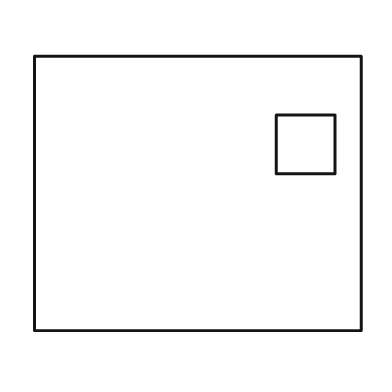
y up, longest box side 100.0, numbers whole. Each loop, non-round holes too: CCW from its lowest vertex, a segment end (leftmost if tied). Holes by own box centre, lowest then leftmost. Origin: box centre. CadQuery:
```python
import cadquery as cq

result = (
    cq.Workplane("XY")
    .moveTo(-50.0, -42.0)
    .lineTo(50.0, -42.0)
    .lineTo(50.0, 42.0)
    .lineTo(-50.0, 42.0)
    .close()
    .moveTo(24.0, 6.0)
    .lineTo(42.0, 6.0)
    .lineTo(42.0, 24.0)
    .lineTo(24.0, 24.0)
    .close()
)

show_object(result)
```